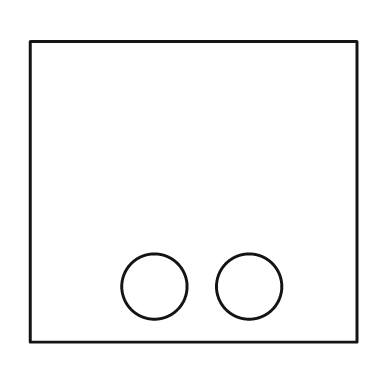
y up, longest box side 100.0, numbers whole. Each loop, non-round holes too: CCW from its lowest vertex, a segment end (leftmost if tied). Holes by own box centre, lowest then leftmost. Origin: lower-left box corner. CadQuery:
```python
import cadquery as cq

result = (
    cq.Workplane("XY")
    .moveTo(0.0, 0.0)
    .lineTo(100.0, 0.0)
    .lineTo(100.0, 92.0)
    .lineTo(0.0, 92.0)
    .close()
    .moveTo(38.0, 17.0)
    .circle(10.0)
    .moveTo(67.0, 17.0)
    .circle(10.0)
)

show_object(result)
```